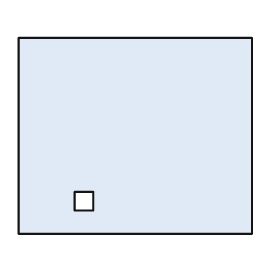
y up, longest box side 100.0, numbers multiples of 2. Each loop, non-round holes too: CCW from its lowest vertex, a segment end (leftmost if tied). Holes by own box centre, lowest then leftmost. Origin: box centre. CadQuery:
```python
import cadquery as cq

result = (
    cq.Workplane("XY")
    .moveTo(-50.0, -42.0)
    .lineTo(50.0, -42.0)
    .lineTo(50.0, 42.0)
    .lineTo(-50.0, 42.0)
    .close()
    .moveTo(-26.0, -32.0)
    .lineTo(-18.0, -32.0)
    .lineTo(-18.0, -24.0)
    .lineTo(-26.0, -24.0)
    .close()
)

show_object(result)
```